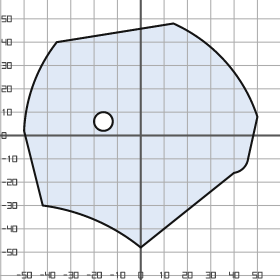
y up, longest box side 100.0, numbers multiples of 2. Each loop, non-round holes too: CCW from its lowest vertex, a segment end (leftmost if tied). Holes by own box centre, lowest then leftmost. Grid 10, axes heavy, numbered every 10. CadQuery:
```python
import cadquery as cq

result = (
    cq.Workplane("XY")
    .moveTo(0.0, -48.0)
    .lineTo(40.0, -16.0)
    .threePointArc((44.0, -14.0), (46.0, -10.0))
    .lineTo(50.0, 8.0)
    .threePointArc((36.0, 32.0), (14.0, 48.0))
    .lineTo(-36.0, 40.0)
    .threePointArc((-46.0, 22.0), (-50.0, 2.0))
    .lineTo(-42.0, -30.0)
    .threePointArc((-20.0, -36.0), (0.0, -48.0))
    .close()
    .moveTo(-16.0, 6.0)
    .circle(4.0)
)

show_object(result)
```